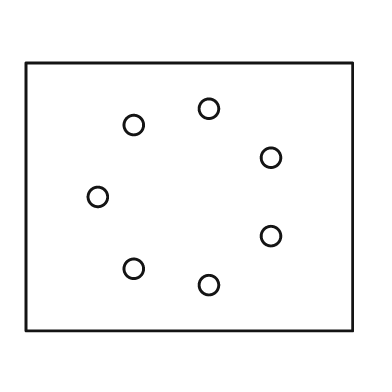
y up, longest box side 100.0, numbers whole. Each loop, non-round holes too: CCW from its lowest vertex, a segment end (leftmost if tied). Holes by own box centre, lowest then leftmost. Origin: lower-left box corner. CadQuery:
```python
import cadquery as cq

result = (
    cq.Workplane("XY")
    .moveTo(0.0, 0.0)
    .lineTo(100.0, 0.0)
    .lineTo(100.0, 82.0)
    .lineTo(0.0, 82.0)
    .close()
    .moveTo(56.0, 14.0)
    .circle(3.0)
    .moveTo(33.0, 19.0)
    .circle(3.0)
    .moveTo(75.0, 29.0)
    .circle(3.0)
    .moveTo(22.0, 41.0)
    .circle(3.0)
    .moveTo(75.0, 53.0)
    .circle(3.0)
    .moveTo(33.0, 63.0)
    .circle(3.0)
    .moveTo(56.0, 68.0)
    .circle(3.0)
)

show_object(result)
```